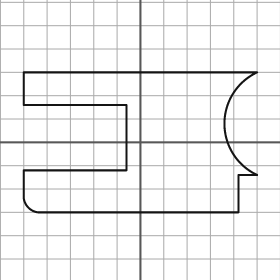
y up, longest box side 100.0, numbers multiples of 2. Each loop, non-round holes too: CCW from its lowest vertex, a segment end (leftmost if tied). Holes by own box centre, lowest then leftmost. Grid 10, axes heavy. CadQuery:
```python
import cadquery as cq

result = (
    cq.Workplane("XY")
    .moveTo(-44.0, -30.0)
    .lineTo(42.0, -30.0)
    .lineTo(42.0, -14.0)
    .lineTo(50.0, -14.0)
    .threePointArc((36.0, 8.0), (50.0, 30.0))
    .lineTo(-50.0, 30.0)
    .lineTo(-50.0, 16.0)
    .lineTo(-6.0, 16.0)
    .lineTo(-6.0, -12.0)
    .lineTo(-50.0, -12.0)
    .lineTo(-50.0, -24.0)
    .threePointArc((-48.0, -28.0), (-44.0, -30.0))
    .close()
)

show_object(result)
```